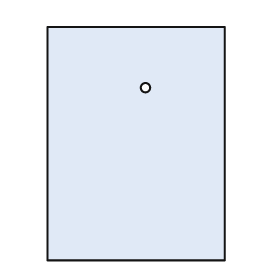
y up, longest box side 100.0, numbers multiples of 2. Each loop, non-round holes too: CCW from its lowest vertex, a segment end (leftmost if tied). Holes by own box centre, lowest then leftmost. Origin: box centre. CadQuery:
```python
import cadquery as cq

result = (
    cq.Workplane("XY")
    .moveTo(-38.0, -50.0)
    .lineTo(38.0, -50.0)
    .lineTo(38.0, 50.0)
    .lineTo(-38.0, 50.0)
    .close()
    .moveTo(4.0, 24.0)
    .circle(2.0)
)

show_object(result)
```